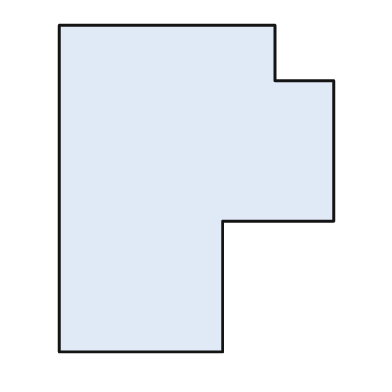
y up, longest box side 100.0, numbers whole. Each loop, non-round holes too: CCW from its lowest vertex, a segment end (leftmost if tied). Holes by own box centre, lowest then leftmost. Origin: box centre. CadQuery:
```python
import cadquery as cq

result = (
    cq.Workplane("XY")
    .moveTo(-42.0, -50.0)
    .lineTo(8.0, -50.0)
    .lineTo(8.0, -10.0)
    .lineTo(42.0, -10.0)
    .lineTo(42.0, 33.0)
    .lineTo(24.0, 33.0)
    .lineTo(24.0, 50.0)
    .lineTo(-42.0, 50.0)
    .close()
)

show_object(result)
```